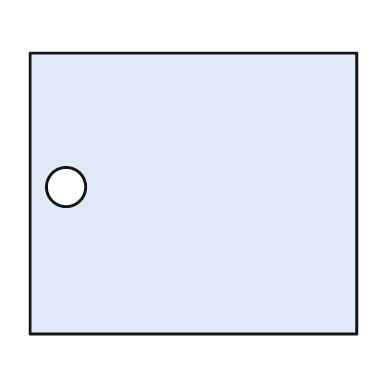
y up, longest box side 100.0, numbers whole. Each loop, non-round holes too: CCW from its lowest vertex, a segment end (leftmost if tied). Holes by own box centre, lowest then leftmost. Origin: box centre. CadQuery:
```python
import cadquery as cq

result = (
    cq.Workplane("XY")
    .moveTo(-50.0, -43.0)
    .lineTo(50.0, -43.0)
    .lineTo(50.0, 43.0)
    .lineTo(-50.0, 43.0)
    .close()
    .moveTo(-39.0, 2.0)
    .circle(6.0)
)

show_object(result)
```